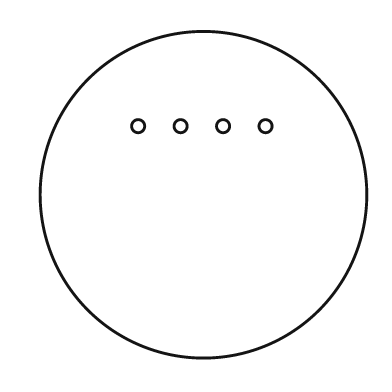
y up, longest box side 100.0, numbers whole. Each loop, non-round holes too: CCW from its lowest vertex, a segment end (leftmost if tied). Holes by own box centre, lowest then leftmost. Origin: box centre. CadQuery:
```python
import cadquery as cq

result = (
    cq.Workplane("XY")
    .moveTo(0.0, 0.0)
    .circle(50.0)
    .moveTo(-20.0, 21.0)
    .circle(2.0)
    .moveTo(-7.0, 21.0)
    .circle(2.0)
    .moveTo(6.0, 21.0)
    .circle(2.0)
    .moveTo(19.0, 21.0)
    .circle(2.0)
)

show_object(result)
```